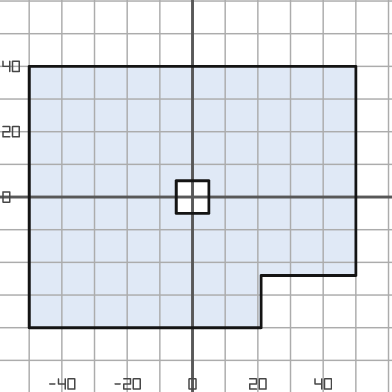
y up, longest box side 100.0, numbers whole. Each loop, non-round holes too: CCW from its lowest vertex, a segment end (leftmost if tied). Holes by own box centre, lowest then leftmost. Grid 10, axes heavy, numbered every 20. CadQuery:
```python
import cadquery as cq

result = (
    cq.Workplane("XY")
    .moveTo(-50.0, -40.0)
    .lineTo(21.0, -40.0)
    .lineTo(21.0, -24.0)
    .lineTo(50.0, -24.0)
    .lineTo(50.0, 40.0)
    .lineTo(-50.0, 40.0)
    .close()
    .moveTo(-5.0, -5.0)
    .lineTo(5.0, -5.0)
    .lineTo(5.0, 5.0)
    .lineTo(-5.0, 5.0)
    .close()
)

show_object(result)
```